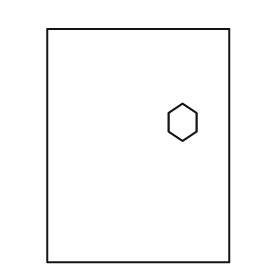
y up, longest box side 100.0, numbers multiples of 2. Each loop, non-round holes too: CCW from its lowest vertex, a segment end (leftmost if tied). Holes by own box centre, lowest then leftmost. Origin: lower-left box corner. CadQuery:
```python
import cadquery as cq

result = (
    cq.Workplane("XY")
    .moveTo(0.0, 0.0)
    .lineTo(78.0, 0.0)
    .lineTo(78.0, 100.0)
    .lineTo(0.0, 100.0)
    .close()
    .moveTo(58.0, 52.0)
    .lineTo(64.0, 56.0)
    .lineTo(64.0, 64.0)
    .lineTo(58.0, 68.0)
    .lineTo(52.0, 64.0)
    .lineTo(52.0, 56.0)
    .close()
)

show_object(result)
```